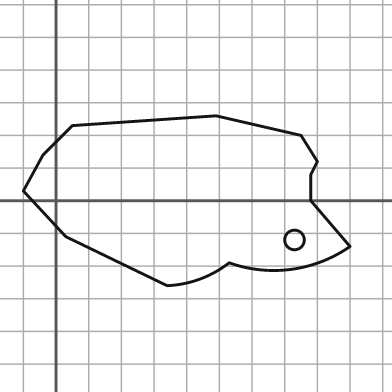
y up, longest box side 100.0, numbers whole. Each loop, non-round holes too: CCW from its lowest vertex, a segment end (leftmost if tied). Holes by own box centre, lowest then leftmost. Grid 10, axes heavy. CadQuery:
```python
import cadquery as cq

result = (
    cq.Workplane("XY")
    .moveTo(34.0, -26.0)
    .threePointArc((44.0, -24.0), (53.0, -19.0))
    .threePointArc((72.0, -21.0), (90.0, -14.0))
    .lineTo(78.0, 0.0)
    .lineTo(78.0, 8.0)
    .lineTo(80.0, 12.0)
    .lineTo(75.0, 20.0)
    .lineTo(49.0, 26.0)
    .lineTo(5.0, 23.0)
    .lineTo(-4.0, 14.0)
    .lineTo(-10.0, 3.0)
    .lineTo(3.0, -11.0)
    .close()
    .moveTo(73.0, -12.0)
    .circle(3.0)
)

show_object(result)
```